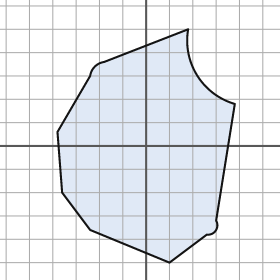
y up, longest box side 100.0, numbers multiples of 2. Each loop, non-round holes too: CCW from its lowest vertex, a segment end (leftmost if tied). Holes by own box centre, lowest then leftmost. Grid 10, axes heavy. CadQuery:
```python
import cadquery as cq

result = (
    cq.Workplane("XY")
    .moveTo(10.0, -50.0)
    .lineTo(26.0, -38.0)
    .threePointArc((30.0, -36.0), (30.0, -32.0))
    .lineTo(38.0, 18.0)
    .threePointArc((22.0, 30.0), (18.0, 50.0))
    .lineTo(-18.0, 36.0)
    .threePointArc((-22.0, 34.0), (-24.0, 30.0))
    .lineTo(-38.0, 6.0)
    .lineTo(-36.0, -20.0)
    .lineTo(-24.0, -36.0)
    .close()
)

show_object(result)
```